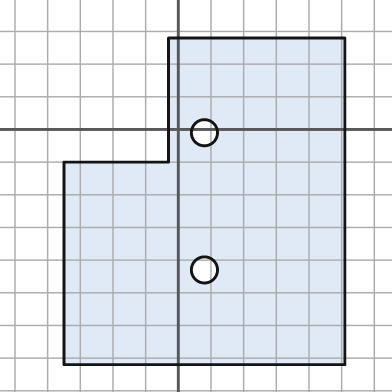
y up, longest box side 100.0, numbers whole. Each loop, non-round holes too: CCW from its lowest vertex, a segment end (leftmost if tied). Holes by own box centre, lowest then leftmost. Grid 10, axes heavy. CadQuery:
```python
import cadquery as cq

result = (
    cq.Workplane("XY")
    .moveTo(-35.0, -72.0)
    .lineTo(51.0, -72.0)
    .lineTo(51.0, 28.0)
    .lineTo(-3.0, 28.0)
    .lineTo(-3.0, -10.0)
    .lineTo(-35.0, -10.0)
    .close()
    .moveTo(8.0, -43.0)
    .circle(4.0)
    .moveTo(8.0, -1.0)
    .circle(4.0)
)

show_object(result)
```